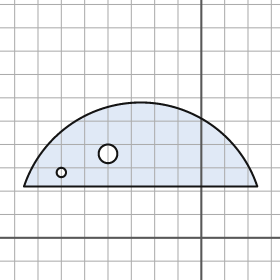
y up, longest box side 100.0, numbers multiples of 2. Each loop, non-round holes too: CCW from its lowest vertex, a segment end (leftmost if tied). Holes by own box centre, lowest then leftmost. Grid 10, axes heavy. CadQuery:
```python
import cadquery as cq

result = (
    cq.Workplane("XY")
    .moveTo(-76.0, 22.0)
    .lineTo(24.0, 22.0)
    .threePointArc((-26.0, 58.0), (-76.0, 22.0))
    .close()
    .moveTo(-60.0, 28.0)
    .circle(2.0)
    .moveTo(-40.0, 36.0)
    .circle(4.0)
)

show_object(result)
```